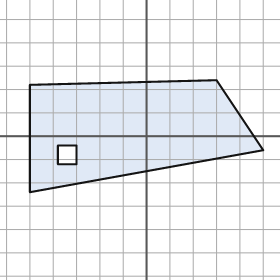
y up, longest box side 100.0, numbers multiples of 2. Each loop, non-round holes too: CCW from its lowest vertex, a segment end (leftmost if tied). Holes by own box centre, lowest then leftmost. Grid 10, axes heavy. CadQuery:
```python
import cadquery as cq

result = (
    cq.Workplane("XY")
    .moveTo(-50.0, -24.0)
    .lineTo(50.0, -6.0)
    .lineTo(30.0, 24.0)
    .lineTo(-50.0, 22.0)
    .close()
    .moveTo(-38.0, -12.0)
    .lineTo(-30.0, -12.0)
    .lineTo(-30.0, -4.0)
    .lineTo(-38.0, -4.0)
    .close()
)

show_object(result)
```